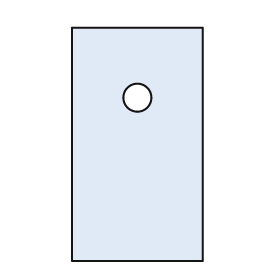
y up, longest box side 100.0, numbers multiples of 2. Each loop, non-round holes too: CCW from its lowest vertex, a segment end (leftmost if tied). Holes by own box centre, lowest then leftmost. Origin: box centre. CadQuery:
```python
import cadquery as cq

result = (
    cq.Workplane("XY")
    .moveTo(-28.0, -50.0)
    .lineTo(28.0, -50.0)
    .lineTo(28.0, 50.0)
    .lineTo(-28.0, 50.0)
    .close()
    .moveTo(0.0, 20.0)
    .circle(6.0)
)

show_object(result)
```